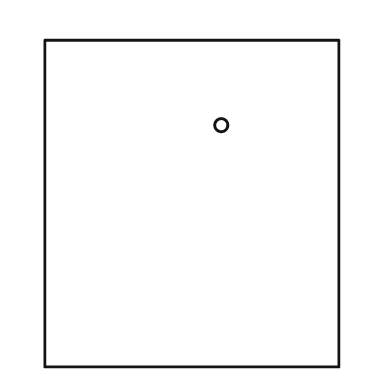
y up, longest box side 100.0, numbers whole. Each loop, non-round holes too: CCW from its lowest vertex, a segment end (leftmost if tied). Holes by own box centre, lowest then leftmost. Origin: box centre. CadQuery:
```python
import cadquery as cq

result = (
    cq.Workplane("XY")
    .moveTo(-45.0, -50.0)
    .lineTo(45.0, -50.0)
    .lineTo(45.0, 50.0)
    .lineTo(-45.0, 50.0)
    .close()
    .moveTo(9.0, 24.0)
    .circle(2.0)
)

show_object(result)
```